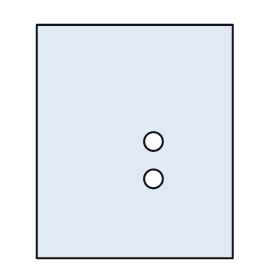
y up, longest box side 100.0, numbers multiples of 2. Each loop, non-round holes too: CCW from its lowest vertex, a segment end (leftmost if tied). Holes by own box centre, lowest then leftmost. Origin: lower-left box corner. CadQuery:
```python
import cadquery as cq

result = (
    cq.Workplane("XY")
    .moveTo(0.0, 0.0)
    .lineTo(84.0, 0.0)
    .lineTo(84.0, 100.0)
    .lineTo(0.0, 100.0)
    .close()
    .moveTo(50.0, 34.0)
    .circle(4.0)
    .moveTo(50.0, 50.0)
    .circle(4.0)
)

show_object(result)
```